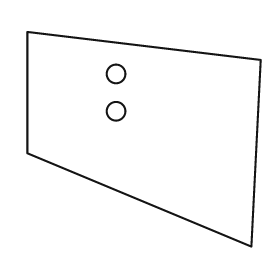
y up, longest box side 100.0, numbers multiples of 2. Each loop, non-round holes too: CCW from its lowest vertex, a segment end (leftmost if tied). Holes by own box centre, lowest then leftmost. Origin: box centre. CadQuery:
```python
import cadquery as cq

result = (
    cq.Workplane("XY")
    .moveTo(46.0, -46.0)
    .lineTo(50.0, 34.0)
    .lineTo(-50.0, 46.0)
    .lineTo(-50.0, -6.0)
    .close()
    .moveTo(-12.0, 12.0)
    .circle(4.0)
    .moveTo(-12.0, 28.0)
    .circle(4.0)
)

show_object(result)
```